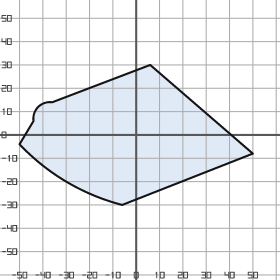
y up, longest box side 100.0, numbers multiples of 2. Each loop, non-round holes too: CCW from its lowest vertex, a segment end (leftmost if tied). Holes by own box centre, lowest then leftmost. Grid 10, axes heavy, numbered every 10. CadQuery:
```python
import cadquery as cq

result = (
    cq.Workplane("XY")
    .moveTo(-6.0, -30.0)
    .lineTo(50.0, -8.0)
    .lineTo(6.0, 30.0)
    .lineTo(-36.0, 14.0)
    .threePointArc((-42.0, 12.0), (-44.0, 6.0))
    .lineTo(-50.0, -4.0)
    .threePointArc((-30.0, -20.0), (-6.0, -30.0))
    .close()
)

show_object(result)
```